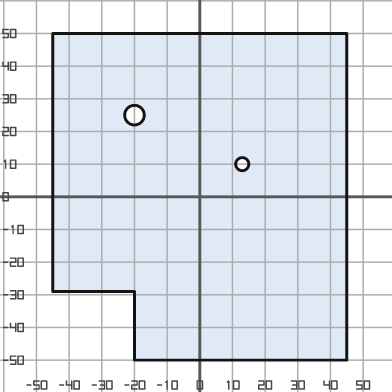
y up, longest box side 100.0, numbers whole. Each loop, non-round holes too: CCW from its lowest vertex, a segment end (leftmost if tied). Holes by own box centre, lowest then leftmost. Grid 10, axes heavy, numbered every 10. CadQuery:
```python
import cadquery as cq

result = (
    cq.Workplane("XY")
    .moveTo(-20.0, -50.0)
    .lineTo(45.0, -50.0)
    .lineTo(45.0, 50.0)
    .lineTo(-45.0, 50.0)
    .lineTo(-45.0, -29.0)
    .lineTo(-20.0, -29.0)
    .close()
    .moveTo(13.0, 10.0)
    .circle(2.0)
    .moveTo(-20.0, 25.0)
    .circle(3.0)
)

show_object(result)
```